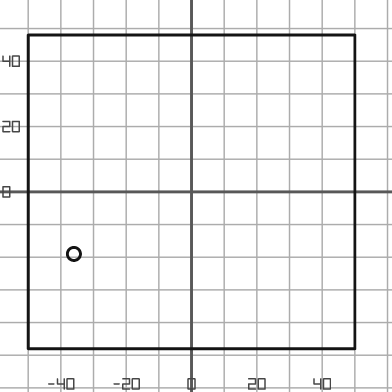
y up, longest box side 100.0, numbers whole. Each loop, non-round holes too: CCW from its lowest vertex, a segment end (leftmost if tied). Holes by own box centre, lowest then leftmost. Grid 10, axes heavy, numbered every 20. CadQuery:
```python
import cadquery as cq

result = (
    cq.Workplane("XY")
    .moveTo(-50.0, -48.0)
    .lineTo(50.0, -48.0)
    .lineTo(50.0, 48.0)
    .lineTo(-50.0, 48.0)
    .close()
    .moveTo(-36.0, -19.0)
    .circle(2.0)
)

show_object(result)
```